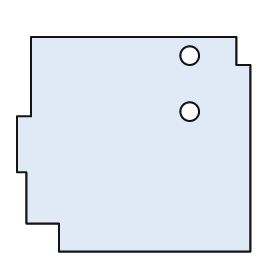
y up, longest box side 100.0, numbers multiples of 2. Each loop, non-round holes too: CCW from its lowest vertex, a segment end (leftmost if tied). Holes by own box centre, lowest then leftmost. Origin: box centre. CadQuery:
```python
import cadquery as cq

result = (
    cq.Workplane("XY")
    .moveTo(-32.0, -46.0)
    .lineTo(50.0, -46.0)
    .lineTo(50.0, 34.0)
    .lineTo(44.0, 34.0)
    .lineTo(44.0, 46.0)
    .lineTo(-44.0, 46.0)
    .lineTo(-44.0, 12.0)
    .lineTo(-50.0, 12.0)
    .lineTo(-50.0, -12.0)
    .lineTo(-46.0, -12.0)
    .lineTo(-46.0, -34.0)
    .lineTo(-32.0, -34.0)
    .close()
    .moveTo(24.0, 14.0)
    .circle(4.0)
    .moveTo(24.0, 38.0)
    .circle(4.0)
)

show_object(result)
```